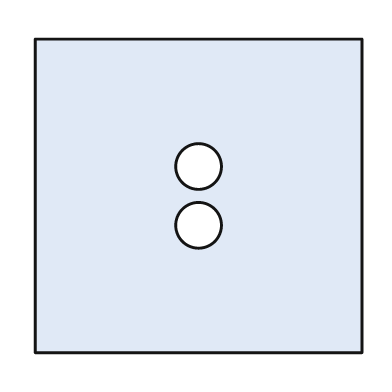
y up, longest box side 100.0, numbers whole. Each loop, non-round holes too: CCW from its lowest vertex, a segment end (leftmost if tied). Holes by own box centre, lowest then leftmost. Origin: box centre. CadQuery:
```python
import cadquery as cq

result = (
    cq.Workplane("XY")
    .moveTo(-50.0, -48.0)
    .lineTo(50.0, -48.0)
    .lineTo(50.0, 48.0)
    .lineTo(-50.0, 48.0)
    .close()
    .moveTo(0.0, -9.0)
    .circle(7.0)
    .moveTo(0.0, 9.0)
    .circle(7.0)
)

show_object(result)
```